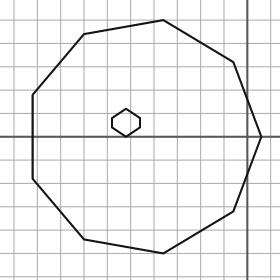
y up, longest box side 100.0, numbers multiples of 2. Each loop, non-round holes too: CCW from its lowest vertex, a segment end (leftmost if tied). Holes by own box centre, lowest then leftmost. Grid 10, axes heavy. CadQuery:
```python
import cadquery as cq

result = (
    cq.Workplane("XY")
    .moveTo(-36.0, -50.0)
    .lineTo(-6.0, -32.0)
    .lineTo(6.0, 0.0)
    .lineTo(-6.0, 32.0)
    .lineTo(-36.0, 50.0)
    .lineTo(-70.0, 44.0)
    .lineTo(-92.0, 18.0)
    .lineTo(-92.0, -18.0)
    .lineTo(-70.0, -44.0)
    .close()
    .moveTo(-52.0, 0.0)
    .lineTo(-46.0, 4.0)
    .lineTo(-46.0, 8.0)
    .lineTo(-52.0, 12.0)
    .lineTo(-58.0, 8.0)
    .lineTo(-58.0, 4.0)
    .close()
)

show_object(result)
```